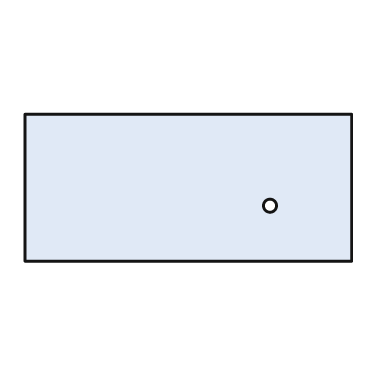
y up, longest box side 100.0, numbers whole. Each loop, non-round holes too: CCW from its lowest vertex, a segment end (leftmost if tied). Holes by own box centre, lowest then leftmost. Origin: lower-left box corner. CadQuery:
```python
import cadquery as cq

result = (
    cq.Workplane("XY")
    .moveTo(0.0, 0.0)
    .lineTo(100.0, 0.0)
    .lineTo(100.0, 45.0)
    .lineTo(0.0, 45.0)
    .close()
    .moveTo(75.0, 17.0)
    .circle(2.0)
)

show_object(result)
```